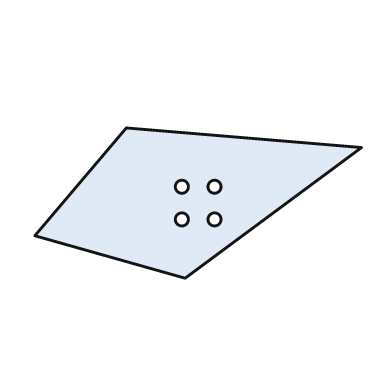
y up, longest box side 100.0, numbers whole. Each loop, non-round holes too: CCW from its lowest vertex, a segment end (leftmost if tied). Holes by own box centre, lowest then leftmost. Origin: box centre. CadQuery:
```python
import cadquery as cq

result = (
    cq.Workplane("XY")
    .moveTo(-4.0, -23.0)
    .lineTo(50.0, 17.0)
    .lineTo(-22.0, 23.0)
    .lineTo(-50.0, -10.0)
    .close()
    .moveTo(-5.0, -5.0)
    .circle(2.0)
    .moveTo(5.0, -5.0)
    .circle(2.0)
    .moveTo(-5.0, 5.0)
    .circle(2.0)
    .moveTo(5.0, 5.0)
    .circle(2.0)
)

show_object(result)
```